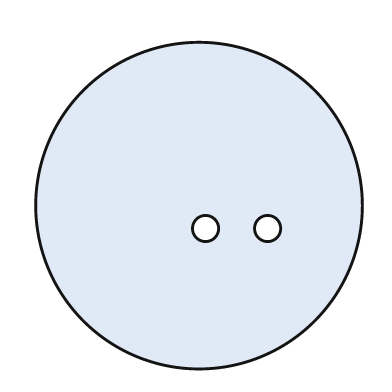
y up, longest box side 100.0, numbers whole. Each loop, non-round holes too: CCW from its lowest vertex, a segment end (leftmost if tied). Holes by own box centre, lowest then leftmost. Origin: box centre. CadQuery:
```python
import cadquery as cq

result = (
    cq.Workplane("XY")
    .moveTo(0.0, 0.0)
    .circle(50.0)
    .moveTo(2.0, -7.0)
    .circle(4.0)
    .moveTo(21.0, -7.0)
    .circle(4.0)
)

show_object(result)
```